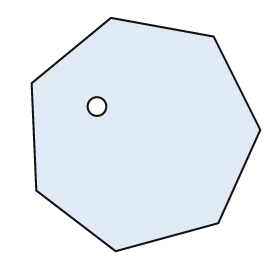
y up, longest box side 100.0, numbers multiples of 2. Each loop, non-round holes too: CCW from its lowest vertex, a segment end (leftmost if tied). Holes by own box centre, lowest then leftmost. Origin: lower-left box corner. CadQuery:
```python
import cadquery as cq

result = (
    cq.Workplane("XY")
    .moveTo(36.0, 0.0)
    .lineTo(80.0, 12.0)
    .lineTo(98.0, 52.0)
    .lineTo(78.0, 92.0)
    .lineTo(34.0, 100.0)
    .lineTo(0.0, 72.0)
    .lineTo(2.0, 26.0)
    .close()
    .moveTo(28.0, 62.0)
    .circle(4.0)
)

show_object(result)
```